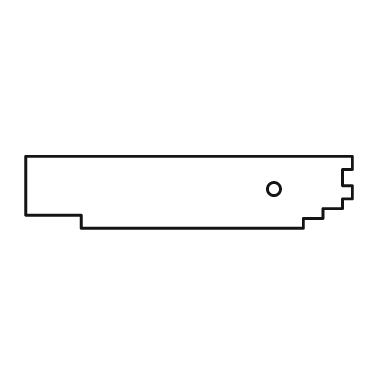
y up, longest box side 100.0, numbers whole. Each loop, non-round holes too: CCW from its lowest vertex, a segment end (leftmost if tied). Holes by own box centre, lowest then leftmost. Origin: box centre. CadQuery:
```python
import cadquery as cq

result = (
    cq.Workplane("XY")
    .moveTo(-33.0, -11.0)
    .lineTo(35.0, -11.0)
    .lineTo(35.0, -8.0)
    .lineTo(41.0, -8.0)
    .lineTo(41.0, -5.0)
    .lineTo(47.0, -5.0)
    .lineTo(47.0, -2.0)
    .lineTo(50.0, -2.0)
    .lineTo(50.0, 2.0)
    .lineTo(47.0, 2.0)
    .lineTo(47.0, 7.0)
    .lineTo(50.0, 7.0)
    .lineTo(50.0, 11.0)
    .lineTo(-50.0, 11.0)
    .lineTo(-50.0, -7.0)
    .lineTo(-33.0, -7.0)
    .close()
    .moveTo(26.0, 1.0)
    .circle(2.0)
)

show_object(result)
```